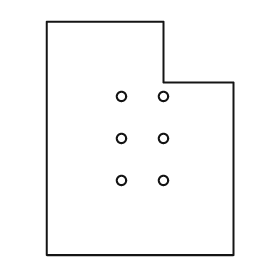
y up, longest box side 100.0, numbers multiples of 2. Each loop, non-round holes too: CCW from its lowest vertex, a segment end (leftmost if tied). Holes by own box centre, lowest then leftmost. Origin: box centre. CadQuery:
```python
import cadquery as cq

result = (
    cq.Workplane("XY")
    .moveTo(-40.0, -50.0)
    .lineTo(40.0, -50.0)
    .lineTo(40.0, 24.0)
    .lineTo(10.0, 24.0)
    .lineTo(10.0, 50.0)
    .lineTo(-40.0, 50.0)
    .close()
    .moveTo(-8.0, -18.0)
    .circle(2.0)
    .moveTo(10.0, -18.0)
    .circle(2.0)
    .moveTo(-8.0, 0.0)
    .circle(2.0)
    .moveTo(10.0, 0.0)
    .circle(2.0)
    .moveTo(-8.0, 18.0)
    .circle(2.0)
    .moveTo(10.0, 18.0)
    .circle(2.0)
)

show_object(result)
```